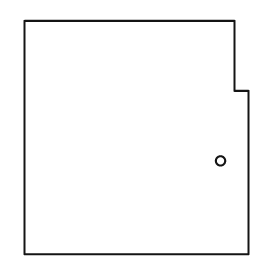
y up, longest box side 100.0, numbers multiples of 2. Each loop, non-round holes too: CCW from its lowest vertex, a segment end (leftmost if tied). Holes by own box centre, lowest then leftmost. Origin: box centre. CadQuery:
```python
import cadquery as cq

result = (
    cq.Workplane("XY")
    .moveTo(-48.0, -50.0)
    .lineTo(48.0, -50.0)
    .lineTo(48.0, 20.0)
    .lineTo(42.0, 20.0)
    .lineTo(42.0, 50.0)
    .lineTo(-48.0, 50.0)
    .close()
    .moveTo(36.0, -10.0)
    .circle(2.0)
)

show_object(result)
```